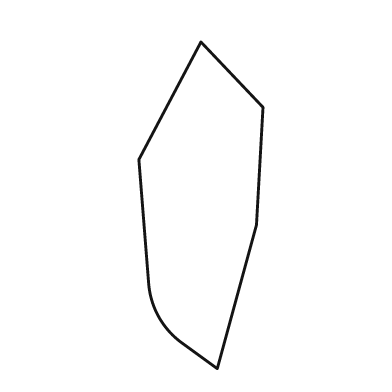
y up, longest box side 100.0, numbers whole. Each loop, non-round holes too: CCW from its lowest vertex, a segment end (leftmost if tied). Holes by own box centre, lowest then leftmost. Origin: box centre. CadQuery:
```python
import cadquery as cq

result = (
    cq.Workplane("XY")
    .moveTo(5.0, -50.0)
    .lineTo(17.0, -6.0)
    .lineTo(19.0, 30.0)
    .lineTo(0.0, 50.0)
    .lineTo(-19.0, 14.0)
    .lineTo(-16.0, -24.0)
    .threePointArc((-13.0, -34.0), (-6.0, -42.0))
    .close()
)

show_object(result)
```